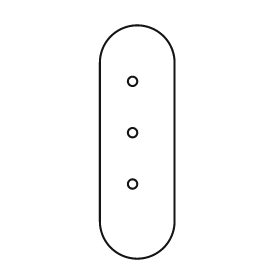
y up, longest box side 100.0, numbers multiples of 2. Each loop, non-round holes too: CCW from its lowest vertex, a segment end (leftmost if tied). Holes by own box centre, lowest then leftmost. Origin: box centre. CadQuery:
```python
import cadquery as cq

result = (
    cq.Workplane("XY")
    .moveTo(-16.0, -34.0)
    .threePointArc((0.0, -50.0), (16.0, -34.0))
    .lineTo(16.0, 34.0)
    .threePointArc((0.0, 50.0), (-16.0, 34.0))
    .close()
    .moveTo(-2.0, -18.0)
    .circle(2.0)
    .moveTo(-2.0, 4.0)
    .circle(2.0)
    .moveTo(-2.0, 26.0)
    .circle(2.0)
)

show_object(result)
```